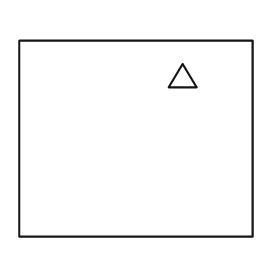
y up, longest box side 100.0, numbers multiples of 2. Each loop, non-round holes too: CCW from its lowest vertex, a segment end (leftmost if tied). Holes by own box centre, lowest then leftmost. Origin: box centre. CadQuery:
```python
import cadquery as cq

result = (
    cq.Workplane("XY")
    .moveTo(-50.0, -42.0)
    .lineTo(50.0, -42.0)
    .lineTo(50.0, 42.0)
    .lineTo(-50.0, 42.0)
    .close()
    .moveTo(14.0, 22.0)
    .lineTo(26.0, 22.0)
    .lineTo(20.0, 32.0)
    .close()
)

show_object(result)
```